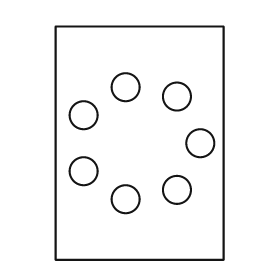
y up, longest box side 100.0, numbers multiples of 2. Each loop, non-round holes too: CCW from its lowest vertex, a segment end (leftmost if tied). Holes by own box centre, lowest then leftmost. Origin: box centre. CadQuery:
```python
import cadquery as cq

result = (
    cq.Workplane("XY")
    .moveTo(-36.0, -50.0)
    .lineTo(36.0, -50.0)
    .lineTo(36.0, 50.0)
    .lineTo(-36.0, 50.0)
    .close()
    .moveTo(-6.0, -24.0)
    .circle(6.0)
    .moveTo(16.0, -20.0)
    .circle(6.0)
    .moveTo(-24.0, -12.0)
    .circle(6.0)
    .moveTo(26.0, 0.0)
    .circle(6.0)
    .moveTo(-24.0, 12.0)
    .circle(6.0)
    .moveTo(16.0, 20.0)
    .circle(6.0)
    .moveTo(-6.0, 24.0)
    .circle(6.0)
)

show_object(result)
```